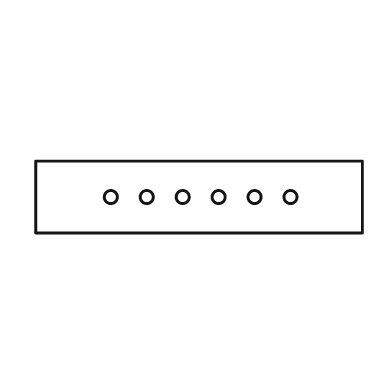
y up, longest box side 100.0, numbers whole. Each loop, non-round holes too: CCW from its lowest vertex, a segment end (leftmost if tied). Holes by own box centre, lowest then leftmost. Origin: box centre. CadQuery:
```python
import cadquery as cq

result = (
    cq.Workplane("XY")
    .moveTo(-50.0, -11.0)
    .lineTo(50.0, -11.0)
    .lineTo(50.0, 11.0)
    .lineTo(-50.0, 11.0)
    .close()
    .moveTo(-27.0, 0.0)
    .circle(2.0)
    .moveTo(-16.0, 0.0)
    .circle(2.0)
    .moveTo(-5.0, 0.0)
    .circle(2.0)
    .moveTo(6.0, 0.0)
    .circle(2.0)
    .moveTo(17.0, 0.0)
    .circle(2.0)
    .moveTo(28.0, 0.0)
    .circle(2.0)
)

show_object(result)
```